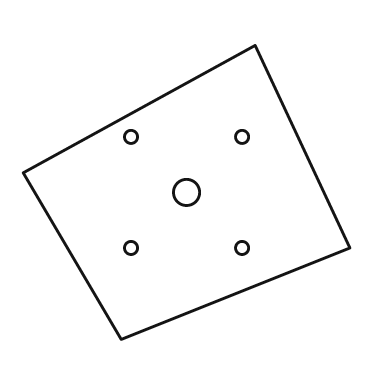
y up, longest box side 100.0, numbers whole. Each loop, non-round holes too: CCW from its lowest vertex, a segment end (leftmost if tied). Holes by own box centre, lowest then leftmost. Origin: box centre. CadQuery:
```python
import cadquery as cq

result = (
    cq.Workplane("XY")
    .moveTo(-20.0, -45.0)
    .lineTo(50.0, -17.0)
    .lineTo(21.0, 45.0)
    .lineTo(-50.0, 6.0)
    .close()
    .moveTo(-17.0, -17.0)
    .circle(2.0)
    .moveTo(17.0, -17.0)
    .circle(2.0)
    .moveTo(0.0, 0.0)
    .circle(4.0)
    .moveTo(-17.0, 17.0)
    .circle(2.0)
    .moveTo(17.0, 17.0)
    .circle(2.0)
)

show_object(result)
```